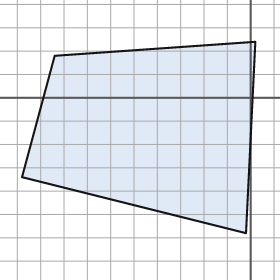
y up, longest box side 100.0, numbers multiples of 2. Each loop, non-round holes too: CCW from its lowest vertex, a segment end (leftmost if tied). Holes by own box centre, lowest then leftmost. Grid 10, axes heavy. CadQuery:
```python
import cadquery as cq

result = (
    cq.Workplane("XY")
    .moveTo(-2.0, -58.0)
    .lineTo(2.0, 24.0)
    .lineTo(-84.0, 18.0)
    .lineTo(-98.0, -34.0)
    .close()
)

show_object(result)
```